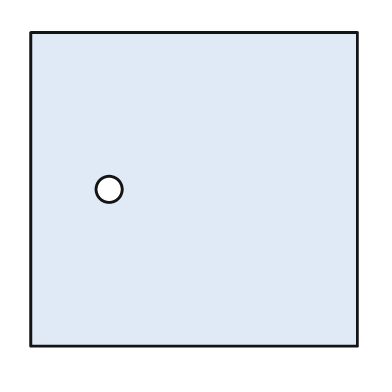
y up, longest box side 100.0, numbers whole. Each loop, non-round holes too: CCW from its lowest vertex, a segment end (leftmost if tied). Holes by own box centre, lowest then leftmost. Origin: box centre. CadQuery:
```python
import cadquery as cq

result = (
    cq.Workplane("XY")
    .moveTo(-50.0, -48.0)
    .lineTo(50.0, -48.0)
    .lineTo(50.0, 48.0)
    .lineTo(-50.0, 48.0)
    .close()
    .moveTo(-26.0, 0.0)
    .circle(4.0)
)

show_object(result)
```